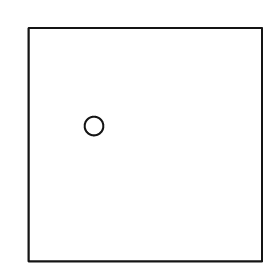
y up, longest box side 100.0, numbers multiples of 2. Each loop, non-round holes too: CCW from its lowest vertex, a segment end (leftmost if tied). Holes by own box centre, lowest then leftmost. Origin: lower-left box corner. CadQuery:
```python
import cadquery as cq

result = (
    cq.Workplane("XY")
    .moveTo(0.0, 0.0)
    .lineTo(100.0, 0.0)
    .lineTo(100.0, 100.0)
    .lineTo(0.0, 100.0)
    .close()
    .moveTo(28.0, 58.0)
    .circle(4.0)
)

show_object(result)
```